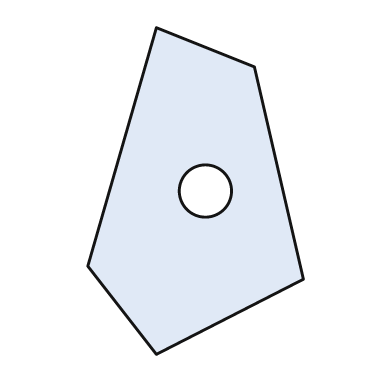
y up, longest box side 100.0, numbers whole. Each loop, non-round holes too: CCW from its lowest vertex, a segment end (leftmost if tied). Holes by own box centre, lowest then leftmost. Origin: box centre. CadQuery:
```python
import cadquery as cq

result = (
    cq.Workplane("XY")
    .moveTo(-12.0, -50.0)
    .lineTo(33.0, -27.0)
    .lineTo(18.0, 38.0)
    .lineTo(-12.0, 50.0)
    .lineTo(-33.0, -23.0)
    .close()
    .moveTo(3.0, 0.0)
    .circle(8.0)
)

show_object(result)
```